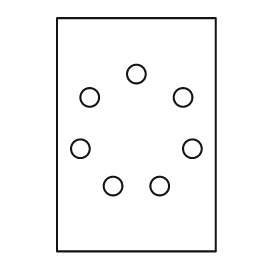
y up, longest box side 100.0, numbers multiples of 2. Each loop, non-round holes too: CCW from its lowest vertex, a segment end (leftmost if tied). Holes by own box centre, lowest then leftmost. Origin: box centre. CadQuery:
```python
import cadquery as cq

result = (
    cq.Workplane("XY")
    .moveTo(-34.0, -50.0)
    .lineTo(34.0, -50.0)
    .lineTo(34.0, 50.0)
    .lineTo(-34.0, 50.0)
    .close()
    .moveTo(-10.0, -22.0)
    .circle(4.0)
    .moveTo(10.0, -22.0)
    .circle(4.0)
    .moveTo(-24.0, -6.0)
    .circle(4.0)
    .moveTo(24.0, -6.0)
    .circle(4.0)
    .moveTo(-20.0, 16.0)
    .circle(4.0)
    .moveTo(20.0, 16.0)
    .circle(4.0)
    .moveTo(0.0, 26.0)
    .circle(4.0)
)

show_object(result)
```